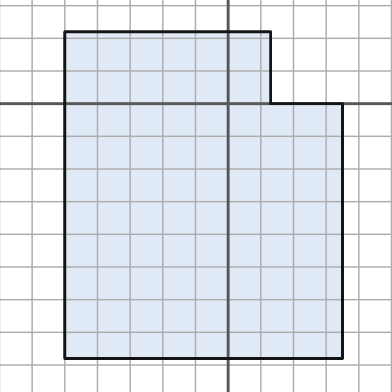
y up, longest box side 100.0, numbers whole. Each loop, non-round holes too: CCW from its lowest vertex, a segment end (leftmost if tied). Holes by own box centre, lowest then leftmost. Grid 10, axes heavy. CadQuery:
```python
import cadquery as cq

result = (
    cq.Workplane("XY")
    .moveTo(-50.0, -78.0)
    .lineTo(35.0, -78.0)
    .lineTo(35.0, 0.0)
    .lineTo(13.0, 0.0)
    .lineTo(13.0, 22.0)
    .lineTo(-50.0, 22.0)
    .close()
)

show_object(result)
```